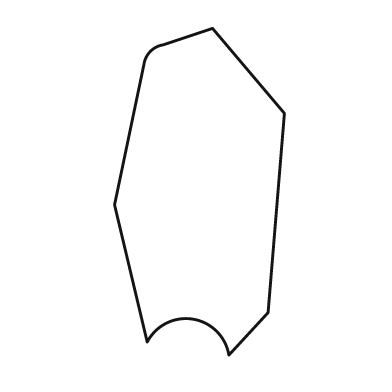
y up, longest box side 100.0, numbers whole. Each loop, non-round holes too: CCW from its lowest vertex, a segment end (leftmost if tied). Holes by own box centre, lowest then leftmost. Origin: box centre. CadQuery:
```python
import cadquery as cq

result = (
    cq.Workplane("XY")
    .moveTo(9.0, -50.0)
    .lineTo(21.0, -37.0)
    .lineTo(26.0, 24.0)
    .lineTo(4.0, 50.0)
    .lineTo(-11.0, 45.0)
    .threePointArc((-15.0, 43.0), (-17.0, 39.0))
    .lineTo(-26.0, -4.0)
    .lineTo(-16.0, -46.0)
    .threePointArc((-2.0, -39.0), (9.0, -50.0))
    .close()
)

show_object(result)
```